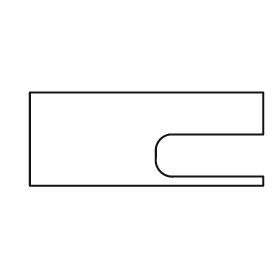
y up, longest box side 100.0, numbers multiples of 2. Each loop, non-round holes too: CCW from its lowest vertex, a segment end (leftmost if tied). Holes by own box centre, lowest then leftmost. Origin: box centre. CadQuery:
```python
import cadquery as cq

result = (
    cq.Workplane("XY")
    .moveTo(-50.0, -20.0)
    .lineTo(50.0, -20.0)
    .lineTo(50.0, -16.0)
    .lineTo(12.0, -16.0)
    .threePointArc((6.0, -14.0), (4.0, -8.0))
    .lineTo(4.0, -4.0)
    .threePointArc((6.0, 0.0), (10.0, 2.0))
    .lineTo(50.0, 2.0)
    .lineTo(50.0, 20.0)
    .lineTo(-50.0, 20.0)
    .close()
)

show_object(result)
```